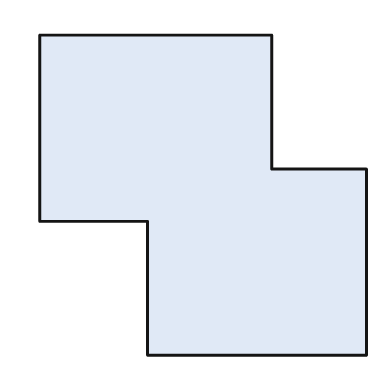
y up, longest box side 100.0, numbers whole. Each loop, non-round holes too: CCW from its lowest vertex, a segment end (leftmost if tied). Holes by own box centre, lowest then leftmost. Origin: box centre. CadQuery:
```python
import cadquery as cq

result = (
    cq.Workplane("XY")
    .moveTo(-17.0, -49.0)
    .lineTo(50.0, -49.0)
    .lineTo(50.0, 8.0)
    .lineTo(21.0, 8.0)
    .lineTo(21.0, 49.0)
    .lineTo(-50.0, 49.0)
    .lineTo(-50.0, -8.0)
    .lineTo(-17.0, -8.0)
    .close()
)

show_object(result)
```